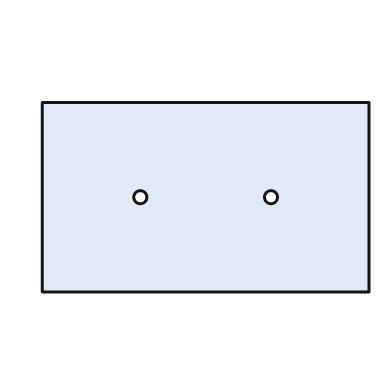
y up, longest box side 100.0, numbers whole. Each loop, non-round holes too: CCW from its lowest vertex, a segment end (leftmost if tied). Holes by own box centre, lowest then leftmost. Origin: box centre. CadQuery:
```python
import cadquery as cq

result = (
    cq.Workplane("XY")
    .moveTo(-50.0, -29.0)
    .lineTo(50.0, -29.0)
    .lineTo(50.0, 29.0)
    .lineTo(-50.0, 29.0)
    .close()
    .moveTo(-20.0, 0.0)
    .circle(2.0)
    .moveTo(20.0, 0.0)
    .circle(2.0)
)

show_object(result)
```